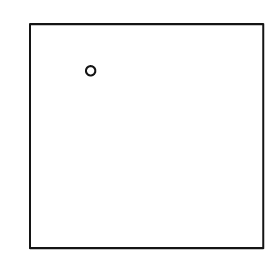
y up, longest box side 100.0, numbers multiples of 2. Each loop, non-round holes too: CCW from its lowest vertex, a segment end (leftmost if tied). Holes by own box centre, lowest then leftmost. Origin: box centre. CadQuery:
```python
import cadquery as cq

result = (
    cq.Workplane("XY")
    .moveTo(-50.0, -48.0)
    .lineTo(50.0, -48.0)
    .lineTo(50.0, 48.0)
    .lineTo(-50.0, 48.0)
    .close()
    .moveTo(-24.0, 28.0)
    .circle(2.0)
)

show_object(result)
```